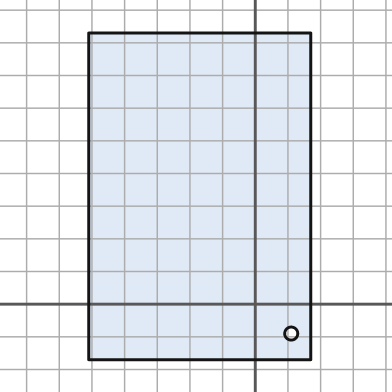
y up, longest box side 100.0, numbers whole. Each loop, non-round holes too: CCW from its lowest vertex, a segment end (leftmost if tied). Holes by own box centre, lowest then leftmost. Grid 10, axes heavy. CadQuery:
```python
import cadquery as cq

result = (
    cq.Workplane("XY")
    .moveTo(-51.0, -17.0)
    .lineTo(17.0, -17.0)
    .lineTo(17.0, 83.0)
    .lineTo(-51.0, 83.0)
    .close()
    .moveTo(11.0, -9.0)
    .circle(2.0)
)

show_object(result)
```